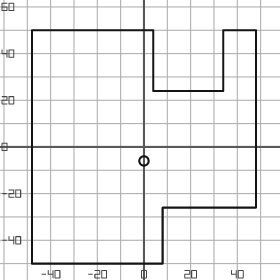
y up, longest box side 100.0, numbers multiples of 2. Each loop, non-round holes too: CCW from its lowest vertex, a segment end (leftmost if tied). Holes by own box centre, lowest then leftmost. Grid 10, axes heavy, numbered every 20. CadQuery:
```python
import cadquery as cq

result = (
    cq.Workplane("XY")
    .moveTo(-48.0, -50.0)
    .lineTo(8.0, -50.0)
    .lineTo(8.0, -26.0)
    .lineTo(48.0, -26.0)
    .lineTo(48.0, 50.0)
    .lineTo(34.0, 50.0)
    .lineTo(34.0, 24.0)
    .lineTo(4.0, 24.0)
    .lineTo(4.0, 50.0)
    .lineTo(-48.0, 50.0)
    .close()
    .moveTo(0.0, -6.0)
    .circle(2.0)
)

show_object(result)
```